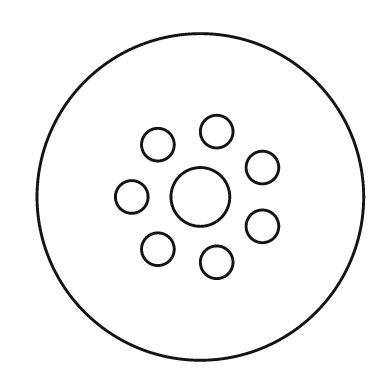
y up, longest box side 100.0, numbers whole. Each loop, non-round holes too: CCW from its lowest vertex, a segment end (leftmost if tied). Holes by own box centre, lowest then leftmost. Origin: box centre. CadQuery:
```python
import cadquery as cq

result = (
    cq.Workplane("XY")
    .moveTo(0.0, 0.0)
    .circle(50.0)
    .moveTo(5.0, -20.0)
    .circle(5.0)
    .moveTo(-13.0, -16.0)
    .circle(5.0)
    .moveTo(19.0, -9.0)
    .circle(5.0)
    .moveTo(-21.0, 0.0)
    .circle(5.0)
    .moveTo(0.0, 0.0)
    .circle(9.0)
    .moveTo(19.0, 9.0)
    .circle(5.0)
    .moveTo(-13.0, 16.0)
    .circle(5.0)
    .moveTo(5.0, 20.0)
    .circle(5.0)
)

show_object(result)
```